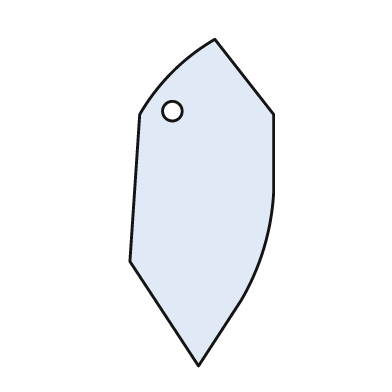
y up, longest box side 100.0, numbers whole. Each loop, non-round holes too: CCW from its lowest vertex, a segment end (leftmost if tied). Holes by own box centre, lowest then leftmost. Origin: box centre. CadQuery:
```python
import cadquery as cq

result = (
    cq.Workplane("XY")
    .moveTo(-1.0, -50.0)
    .lineTo(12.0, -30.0)
    .threePointArc((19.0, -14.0), (22.0, 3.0))
    .lineTo(22.0, 27.0)
    .lineTo(4.0, 50.0)
    .threePointArc((-9.0, 40.0), (-19.0, 27.0))
    .lineTo(-22.0, -18.0)
    .close()
    .moveTo(-9.0, 28.0)
    .circle(3.0)
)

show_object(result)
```